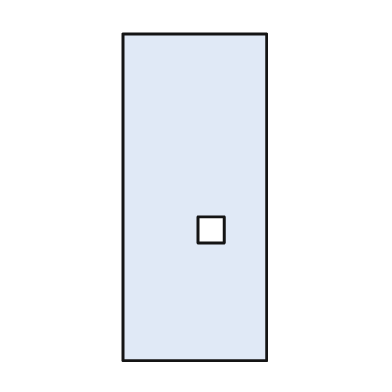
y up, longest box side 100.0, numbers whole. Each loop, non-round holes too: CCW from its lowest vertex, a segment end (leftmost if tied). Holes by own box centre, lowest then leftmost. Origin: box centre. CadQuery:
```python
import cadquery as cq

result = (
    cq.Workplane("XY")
    .moveTo(-22.0, -50.0)
    .lineTo(22.0, -50.0)
    .lineTo(22.0, 50.0)
    .lineTo(-22.0, 50.0)
    .close()
    .moveTo(1.0, -14.0)
    .lineTo(9.0, -14.0)
    .lineTo(9.0, -6.0)
    .lineTo(1.0, -6.0)
    .close()
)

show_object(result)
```